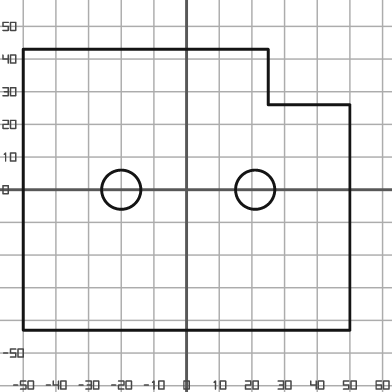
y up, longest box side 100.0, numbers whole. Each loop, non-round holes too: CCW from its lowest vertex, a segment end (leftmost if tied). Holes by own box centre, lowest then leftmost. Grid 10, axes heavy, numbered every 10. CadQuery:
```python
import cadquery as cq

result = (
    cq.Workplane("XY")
    .moveTo(-50.0, -43.0)
    .lineTo(50.0, -43.0)
    .lineTo(50.0, 26.0)
    .lineTo(25.0, 26.0)
    .lineTo(25.0, 43.0)
    .lineTo(-50.0, 43.0)
    .close()
    .moveTo(-20.0, 0.0)
    .circle(6.0)
    .moveTo(21.0, 0.0)
    .circle(6.0)
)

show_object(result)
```